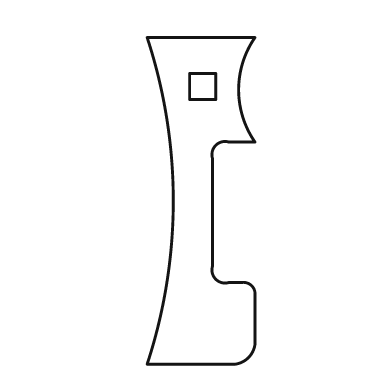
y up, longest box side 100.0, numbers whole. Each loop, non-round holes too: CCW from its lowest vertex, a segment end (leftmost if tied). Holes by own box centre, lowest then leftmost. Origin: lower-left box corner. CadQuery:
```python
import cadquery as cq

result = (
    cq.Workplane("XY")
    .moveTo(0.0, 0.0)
    .lineTo(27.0, 0.0)
    .threePointArc((31.0, 2.0), (33.0, 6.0))
    .lineTo(33.0, 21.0)
    .threePointArc((32.0, 24.0), (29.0, 25.0))
    .lineTo(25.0, 25.0)
    .threePointArc((21.0, 26.0), (20.0, 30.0))
    .lineTo(20.0, 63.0)
    .threePointArc((21.0, 67.0), (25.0, 68.0))
    .lineTo(33.0, 68.0)
    .threePointArc((28.0, 84.0), (33.0, 100.0))
    .lineTo(0.0, 100.0)
    .threePointArc((8.0, 50.0), (0.0, 0.0))
    .close()
    .moveTo(13.0, 81.0)
    .lineTo(21.0, 81.0)
    .lineTo(21.0, 89.0)
    .lineTo(13.0, 89.0)
    .close()
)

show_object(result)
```